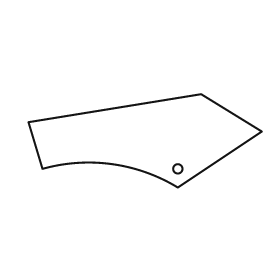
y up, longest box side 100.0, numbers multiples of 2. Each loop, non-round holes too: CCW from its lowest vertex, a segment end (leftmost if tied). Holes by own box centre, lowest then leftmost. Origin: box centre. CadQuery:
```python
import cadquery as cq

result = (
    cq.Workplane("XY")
    .moveTo(14.0, -20.0)
    .lineTo(50.0, 4.0)
    .lineTo(24.0, 20.0)
    .lineTo(-50.0, 8.0)
    .lineTo(-44.0, -12.0)
    .threePointArc((-14.0, -10.0), (14.0, -20.0))
    .close()
    .moveTo(14.0, -12.0)
    .circle(2.0)
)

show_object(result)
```